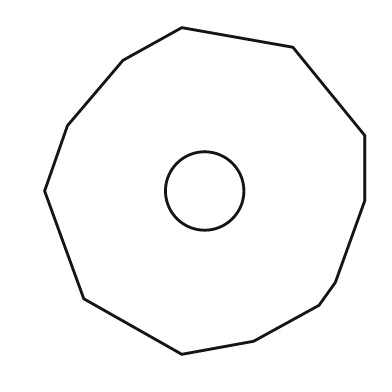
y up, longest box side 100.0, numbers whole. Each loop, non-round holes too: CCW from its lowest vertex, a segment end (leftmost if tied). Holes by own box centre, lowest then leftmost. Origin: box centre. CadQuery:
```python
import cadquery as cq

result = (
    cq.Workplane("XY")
    .moveTo(-7.0, -50.0)
    .lineTo(15.0, -46.0)
    .lineTo(35.0, -35.0)
    .lineTo(40.0, -28.0)
    .lineTo(49.0, -3.0)
    .lineTo(49.0, 17.0)
    .lineTo(27.0, 44.0)
    .lineTo(-7.0, 50.0)
    .lineTo(-25.0, 40.0)
    .lineTo(-42.0, 20.0)
    .lineTo(-49.0, 0.0)
    .lineTo(-37.0, -33.0)
    .close()
    .moveTo(0.0, 0.0)
    .circle(12.0)
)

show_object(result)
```